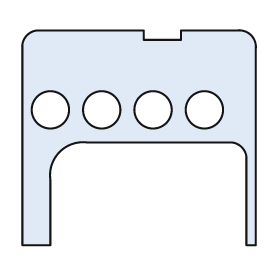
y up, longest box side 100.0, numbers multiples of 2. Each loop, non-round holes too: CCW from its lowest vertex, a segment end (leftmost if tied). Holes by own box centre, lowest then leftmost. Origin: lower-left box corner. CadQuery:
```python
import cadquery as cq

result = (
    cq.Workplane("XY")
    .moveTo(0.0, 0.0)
    .lineTo(12.0, 0.0)
    .lineTo(12.0, 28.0)
    .threePointArc((16.0, 40.0), (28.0, 44.0))
    .lineTo(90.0, 44.0)
    .threePointArc((94.0, 42.0), (96.0, 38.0))
    .lineTo(96.0, 0.0)
    .lineTo(100.0, 0.0)
    .lineTo(100.0, 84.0)
    .threePointArc((98.0, 90.0), (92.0, 92.0))
    .lineTo(68.0, 92.0)
    .lineTo(68.0, 88.0)
    .lineTo(52.0, 88.0)
    .lineTo(52.0, 92.0)
    .lineTo(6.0, 92.0)
    .threePointArc((2.0, 90.0), (0.0, 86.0))
    .close()
    .moveTo(12.0, 58.0)
    .circle(8.0)
    .moveTo(34.0, 58.0)
    .circle(8.0)
    .moveTo(56.0, 58.0)
    .circle(8.0)
    .moveTo(78.0, 58.0)
    .circle(8.0)
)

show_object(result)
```